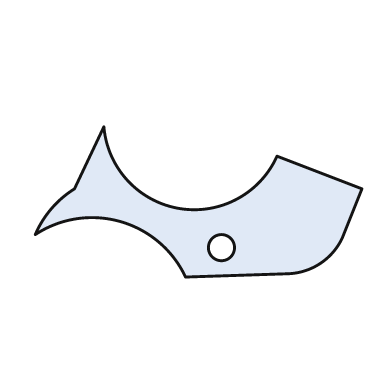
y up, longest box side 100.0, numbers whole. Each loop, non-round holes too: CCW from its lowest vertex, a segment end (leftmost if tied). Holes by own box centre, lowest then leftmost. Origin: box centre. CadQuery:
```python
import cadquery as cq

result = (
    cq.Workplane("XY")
    .moveTo(-4.0, -23.0)
    .lineTo(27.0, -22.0)
    .threePointArc((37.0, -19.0), (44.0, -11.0))
    .lineTo(50.0, 4.0)
    .lineTo(24.0, 14.0)
    .threePointArc((-6.0, -2.0), (-29.0, 23.0))
    .lineTo(-38.0, 4.0)
    .threePointArc((-45.0, -2.0), (-50.0, -10.0))
    .threePointArc((-24.0, -6.0), (-4.0, -23.0))
    .close()
    .moveTo(7.0, -14.0)
    .circle(4.0)
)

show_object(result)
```